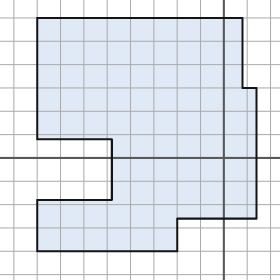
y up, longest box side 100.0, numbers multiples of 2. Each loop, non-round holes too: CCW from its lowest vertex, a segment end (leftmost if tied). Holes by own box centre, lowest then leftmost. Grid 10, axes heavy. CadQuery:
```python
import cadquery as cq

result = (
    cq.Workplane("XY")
    .moveTo(-80.0, -40.0)
    .lineTo(-20.0, -40.0)
    .lineTo(-20.0, -26.0)
    .lineTo(14.0, -26.0)
    .lineTo(14.0, 30.0)
    .lineTo(8.0, 30.0)
    .lineTo(8.0, 60.0)
    .lineTo(-80.0, 60.0)
    .lineTo(-80.0, 8.0)
    .lineTo(-48.0, 8.0)
    .lineTo(-48.0, -18.0)
    .lineTo(-80.0, -18.0)
    .close()
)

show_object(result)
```